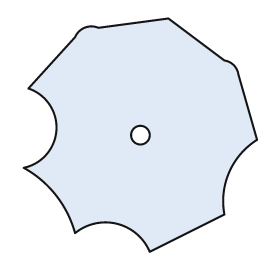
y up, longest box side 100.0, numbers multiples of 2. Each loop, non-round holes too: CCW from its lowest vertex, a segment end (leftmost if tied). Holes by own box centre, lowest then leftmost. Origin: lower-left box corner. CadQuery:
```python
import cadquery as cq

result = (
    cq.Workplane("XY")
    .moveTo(54.0, 0.0)
    .lineTo(86.0, 16.0)
    .threePointArc((88.0, 34.0), (100.0, 48.0))
    .lineTo(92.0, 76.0)
    .threePointArc((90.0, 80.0), (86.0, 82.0))
    .lineTo(62.0, 100.0)
    .lineTo(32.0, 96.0)
    .threePointArc((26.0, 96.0), (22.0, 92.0))
    .lineTo(2.0, 70.0)
    .threePointArc((14.0, 52.0), (0.0, 36.0))
    .threePointArc((14.0, 24.0), (22.0, 8.0))
    .threePointArc((40.0, 12.0), (54.0, 0.0))
    .close()
    .moveTo(50.0, 50.0)
    .circle(4.0)
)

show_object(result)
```